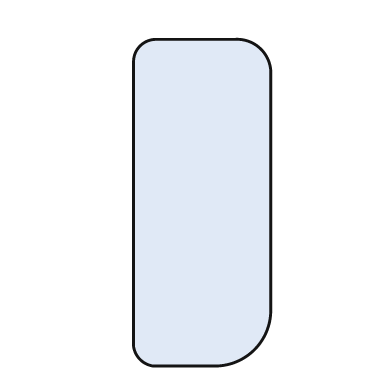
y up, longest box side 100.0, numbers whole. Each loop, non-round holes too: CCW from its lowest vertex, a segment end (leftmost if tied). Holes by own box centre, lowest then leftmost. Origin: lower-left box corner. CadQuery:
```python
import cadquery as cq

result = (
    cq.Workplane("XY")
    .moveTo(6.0, 0.0)
    .lineTo(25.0, 0.0)
    .threePointArc((37.0, 5.0), (42.0, 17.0))
    .lineTo(42.0, 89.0)
    .threePointArc((39.0, 97.0), (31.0, 100.0))
    .lineTo(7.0, 100.0)
    .threePointArc((2.0, 98.0), (0.0, 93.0))
    .lineTo(0.0, 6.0)
    .threePointArc((2.0, 2.0), (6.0, 0.0))
    .close()
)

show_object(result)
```